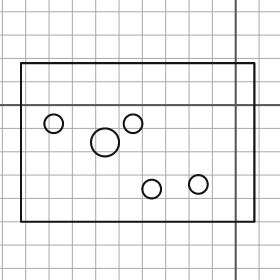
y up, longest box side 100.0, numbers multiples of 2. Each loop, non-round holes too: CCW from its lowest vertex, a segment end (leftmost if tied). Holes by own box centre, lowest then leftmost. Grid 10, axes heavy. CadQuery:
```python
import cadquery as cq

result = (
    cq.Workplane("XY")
    .moveTo(-92.0, -50.0)
    .lineTo(8.0, -50.0)
    .lineTo(8.0, 18.0)
    .lineTo(-92.0, 18.0)
    .close()
    .moveTo(-36.0, -36.0)
    .circle(4.0)
    .moveTo(-16.0, -34.0)
    .circle(4.0)
    .moveTo(-56.0, -16.0)
    .circle(6.0)
    .moveTo(-78.0, -8.0)
    .circle(4.0)
    .moveTo(-44.0, -8.0)
    .circle(4.0)
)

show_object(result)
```